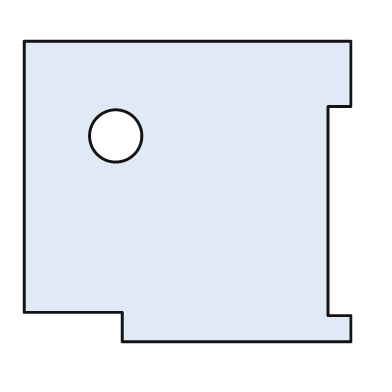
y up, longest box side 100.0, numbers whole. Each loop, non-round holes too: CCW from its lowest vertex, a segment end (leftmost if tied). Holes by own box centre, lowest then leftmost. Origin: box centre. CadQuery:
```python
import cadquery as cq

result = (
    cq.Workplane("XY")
    .moveTo(-20.0, -46.0)
    .lineTo(50.0, -46.0)
    .lineTo(50.0, -38.0)
    .lineTo(43.0, -38.0)
    .lineTo(43.0, 26.0)
    .lineTo(50.0, 26.0)
    .lineTo(50.0, 46.0)
    .lineTo(-50.0, 46.0)
    .lineTo(-50.0, -37.0)
    .lineTo(-20.0, -37.0)
    .close()
    .moveTo(-22.0, 17.0)
    .circle(8.0)
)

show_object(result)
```